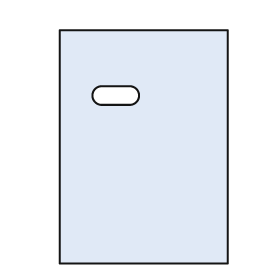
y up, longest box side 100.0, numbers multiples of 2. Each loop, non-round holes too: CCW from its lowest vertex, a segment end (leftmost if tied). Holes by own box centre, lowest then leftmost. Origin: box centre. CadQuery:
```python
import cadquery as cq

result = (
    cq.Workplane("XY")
    .moveTo(-36.0, -50.0)
    .lineTo(36.0, -50.0)
    .lineTo(36.0, 50.0)
    .lineTo(-36.0, 50.0)
    .close()
    .moveTo(-18.0, 18.0)
    .lineTo(-6.0, 18.0)
    .threePointArc((-2.0, 22.0), (-6.0, 26.0))
    .lineTo(-18.0, 26.0)
    .threePointArc((-22.0, 22.0), (-18.0, 18.0))
    .close()
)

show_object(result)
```